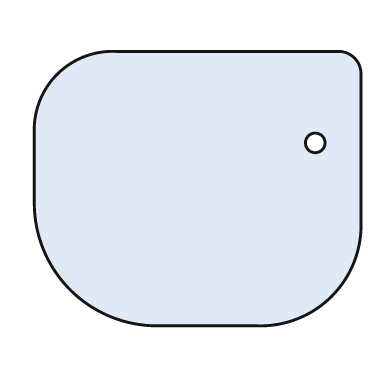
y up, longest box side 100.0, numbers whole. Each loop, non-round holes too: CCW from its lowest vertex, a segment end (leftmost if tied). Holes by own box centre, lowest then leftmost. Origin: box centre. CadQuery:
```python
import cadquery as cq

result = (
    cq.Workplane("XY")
    .moveTo(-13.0, -42.0)
    .lineTo(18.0, -42.0)
    .threePointArc((41.0, -33.0), (50.0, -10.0))
    .lineTo(50.0, 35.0)
    .threePointArc((48.0, 40.0), (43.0, 42.0))
    .lineTo(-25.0, 42.0)
    .threePointArc((-43.0, 35.0), (-50.0, 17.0))
    .lineTo(-50.0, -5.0)
    .threePointArc((-39.0, -31.0), (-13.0, -42.0))
    .close()
    .moveTo(36.0, 14.0)
    .circle(3.0)
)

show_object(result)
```